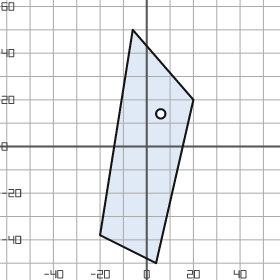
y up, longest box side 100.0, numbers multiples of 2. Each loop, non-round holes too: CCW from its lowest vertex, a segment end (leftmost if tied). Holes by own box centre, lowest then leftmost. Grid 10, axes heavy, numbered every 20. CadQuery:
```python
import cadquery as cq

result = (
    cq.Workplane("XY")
    .moveTo(4.0, -50.0)
    .lineTo(20.0, 20.0)
    .lineTo(-6.0, 50.0)
    .lineTo(-20.0, -38.0)
    .close()
    .moveTo(6.0, 14.0)
    .circle(2.0)
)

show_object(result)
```